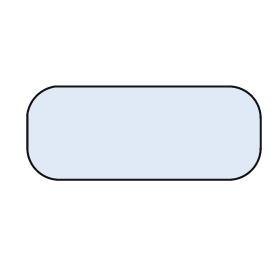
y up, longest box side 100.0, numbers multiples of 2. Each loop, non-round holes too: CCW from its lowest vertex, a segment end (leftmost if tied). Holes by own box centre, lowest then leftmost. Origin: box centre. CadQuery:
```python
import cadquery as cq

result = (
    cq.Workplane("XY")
    .moveTo(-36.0, -20.0)
    .lineTo(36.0, -20.0)
    .threePointArc((46.0, -16.0), (50.0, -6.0))
    .lineTo(50.0, 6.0)
    .threePointArc((46.0, 16.0), (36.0, 20.0))
    .lineTo(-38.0, 20.0)
    .threePointArc((-46.0, 16.0), (-50.0, 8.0))
    .lineTo(-50.0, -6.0)
    .threePointArc((-46.0, -16.0), (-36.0, -20.0))
    .close()
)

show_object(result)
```